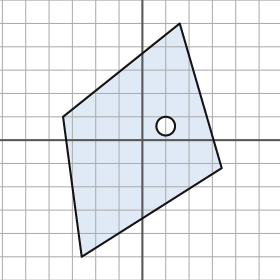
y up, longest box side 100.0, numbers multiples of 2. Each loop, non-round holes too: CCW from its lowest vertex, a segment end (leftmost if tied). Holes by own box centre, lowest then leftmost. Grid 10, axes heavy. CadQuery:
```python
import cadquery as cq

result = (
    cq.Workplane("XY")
    .moveTo(-26.0, -50.0)
    .lineTo(34.0, -12.0)
    .lineTo(16.0, 50.0)
    .lineTo(-34.0, 10.0)
    .close()
    .moveTo(10.0, 6.0)
    .circle(4.0)
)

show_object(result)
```